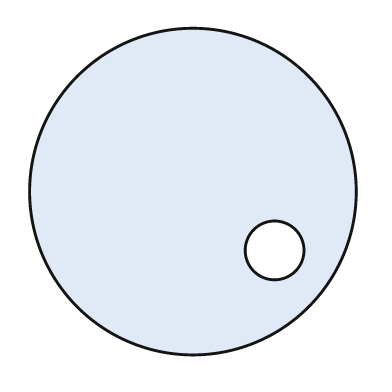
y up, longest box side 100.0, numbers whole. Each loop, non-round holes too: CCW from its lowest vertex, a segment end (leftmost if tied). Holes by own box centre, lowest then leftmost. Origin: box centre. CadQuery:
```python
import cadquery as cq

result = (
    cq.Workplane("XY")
    .moveTo(0.0, 0.0)
    .circle(50.0)
    .moveTo(25.0, -18.0)
    .circle(9.0)
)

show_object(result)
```